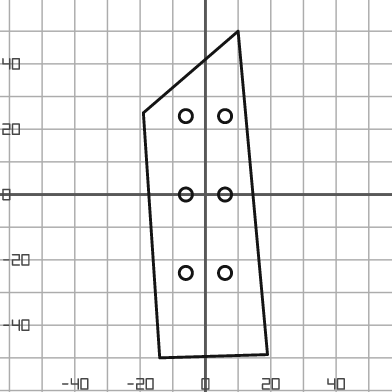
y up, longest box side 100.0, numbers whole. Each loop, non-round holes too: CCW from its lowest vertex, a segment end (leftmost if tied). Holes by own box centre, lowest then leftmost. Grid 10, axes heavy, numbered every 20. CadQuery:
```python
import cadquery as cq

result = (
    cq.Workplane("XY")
    .moveTo(-14.0, -50.0)
    .lineTo(19.0, -49.0)
    .lineTo(10.0, 50.0)
    .lineTo(-19.0, 25.0)
    .close()
    .moveTo(-6.0, -24.0)
    .circle(2.0)
    .moveTo(6.0, -24.0)
    .circle(2.0)
    .moveTo(-6.0, 0.0)
    .circle(2.0)
    .moveTo(6.0, 0.0)
    .circle(2.0)
    .moveTo(-6.0, 24.0)
    .circle(2.0)
    .moveTo(6.0, 24.0)
    .circle(2.0)
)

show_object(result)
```